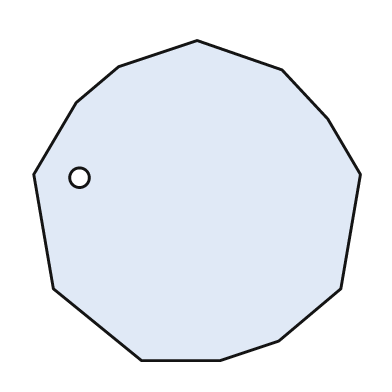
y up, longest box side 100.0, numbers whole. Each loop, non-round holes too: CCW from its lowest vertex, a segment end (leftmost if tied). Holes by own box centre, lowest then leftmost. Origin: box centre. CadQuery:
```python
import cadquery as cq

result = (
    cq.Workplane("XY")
    .moveTo(-17.0, -49.0)
    .lineTo(7.0, -49.0)
    .lineTo(25.0, -43.0)
    .lineTo(44.0, -27.0)
    .lineTo(50.0, 8.0)
    .lineTo(40.0, 25.0)
    .lineTo(26.0, 40.0)
    .lineTo(0.0, 49.0)
    .lineTo(-24.0, 41.0)
    .lineTo(-37.0, 30.0)
    .lineTo(-50.0, 8.0)
    .lineTo(-44.0, -27.0)
    .close()
    .moveTo(-36.0, 7.0)
    .circle(3.0)
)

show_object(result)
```